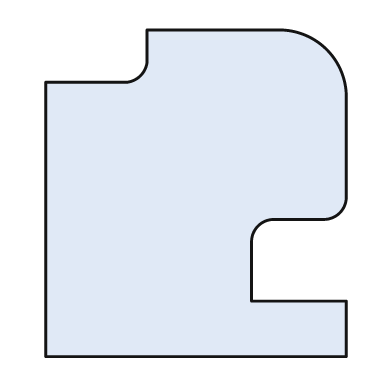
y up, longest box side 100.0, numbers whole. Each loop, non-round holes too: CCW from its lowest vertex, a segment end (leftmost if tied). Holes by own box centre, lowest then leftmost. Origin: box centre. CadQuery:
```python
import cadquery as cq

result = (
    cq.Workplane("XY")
    .moveTo(-46.0, -50.0)
    .lineTo(46.0, -50.0)
    .lineTo(46.0, -33.0)
    .lineTo(17.0, -33.0)
    .lineTo(17.0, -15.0)
    .threePointArc((19.0, -10.0), (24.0, -8.0))
    .lineTo(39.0, -8.0)
    .threePointArc((44.0, -6.0), (46.0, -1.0))
    .lineTo(46.0, 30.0)
    .threePointArc((40.0, 44.0), (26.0, 50.0))
    .lineTo(-15.0, 50.0)
    .lineTo(-15.0, 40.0)
    .threePointArc((-17.0, 36.0), (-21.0, 34.0))
    .lineTo(-46.0, 34.0)
    .close()
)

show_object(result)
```